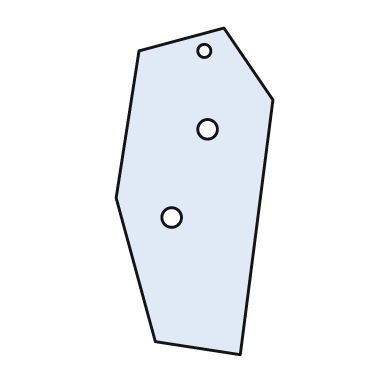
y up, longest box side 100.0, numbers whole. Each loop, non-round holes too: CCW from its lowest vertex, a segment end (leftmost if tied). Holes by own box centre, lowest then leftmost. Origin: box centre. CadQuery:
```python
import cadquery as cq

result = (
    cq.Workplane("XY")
    .moveTo(14.0, -50.0)
    .lineTo(24.0, 28.0)
    .lineTo(9.0, 50.0)
    .lineTo(-17.0, 43.0)
    .lineTo(-24.0, -2.0)
    .lineTo(-12.0, -46.0)
    .close()
    .moveTo(-7.0, -8.0)
    .circle(3.0)
    .moveTo(4.0, 19.0)
    .circle(3.0)
    .moveTo(3.0, 43.0)
    .circle(2.0)
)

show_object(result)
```